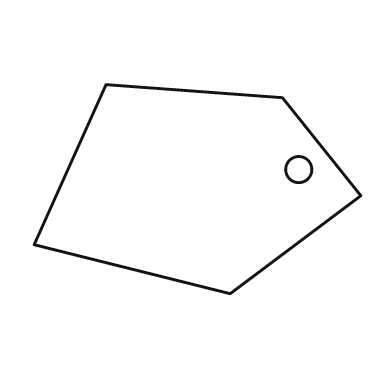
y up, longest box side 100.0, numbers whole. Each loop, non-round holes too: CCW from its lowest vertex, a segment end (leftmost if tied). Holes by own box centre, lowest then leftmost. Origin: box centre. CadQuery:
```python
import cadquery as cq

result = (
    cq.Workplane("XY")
    .moveTo(10.0, -32.0)
    .lineTo(50.0, -2.0)
    .lineTo(26.0, 28.0)
    .lineTo(-28.0, 32.0)
    .lineTo(-50.0, -17.0)
    .close()
    .moveTo(31.0, 6.0)
    .circle(4.0)
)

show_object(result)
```